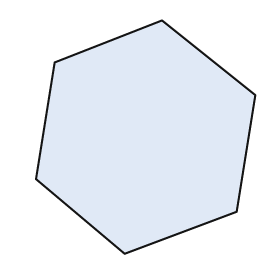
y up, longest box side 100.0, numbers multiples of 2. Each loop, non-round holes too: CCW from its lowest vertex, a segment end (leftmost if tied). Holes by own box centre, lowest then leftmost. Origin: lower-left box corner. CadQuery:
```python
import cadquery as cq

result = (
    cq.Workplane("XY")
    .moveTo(38.0, 0.0)
    .lineTo(86.0, 18.0)
    .lineTo(94.0, 68.0)
    .lineTo(54.0, 100.0)
    .lineTo(8.0, 82.0)
    .lineTo(0.0, 32.0)
    .close()
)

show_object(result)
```